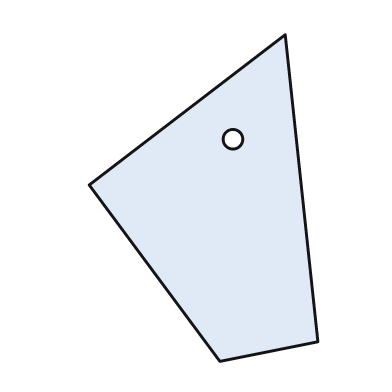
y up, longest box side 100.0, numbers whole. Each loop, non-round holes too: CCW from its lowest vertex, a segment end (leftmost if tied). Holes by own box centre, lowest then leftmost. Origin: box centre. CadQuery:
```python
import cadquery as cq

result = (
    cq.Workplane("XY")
    .moveTo(5.0, -50.0)
    .lineTo(35.0, -44.0)
    .lineTo(25.0, 50.0)
    .lineTo(-35.0, 4.0)
    .close()
    .moveTo(9.0, 18.0)
    .circle(3.0)
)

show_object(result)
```